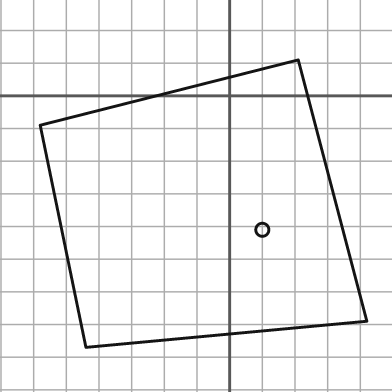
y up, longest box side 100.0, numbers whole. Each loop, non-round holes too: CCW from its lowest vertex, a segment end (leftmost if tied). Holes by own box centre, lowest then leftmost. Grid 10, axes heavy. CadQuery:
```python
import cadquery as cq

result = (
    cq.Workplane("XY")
    .moveTo(-44.0, -77.0)
    .lineTo(42.0, -69.0)
    .lineTo(21.0, 11.0)
    .lineTo(-58.0, -9.0)
    .close()
    .moveTo(10.0, -41.0)
    .circle(2.0)
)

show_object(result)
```